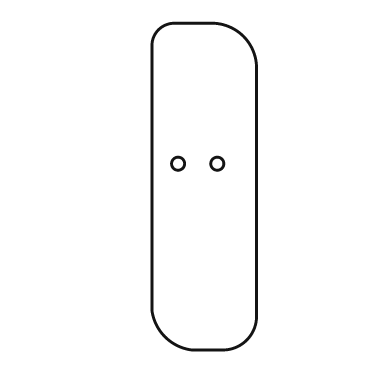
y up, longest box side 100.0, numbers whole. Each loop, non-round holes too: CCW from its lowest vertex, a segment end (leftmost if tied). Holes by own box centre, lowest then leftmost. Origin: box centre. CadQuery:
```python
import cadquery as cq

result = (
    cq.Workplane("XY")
    .moveTo(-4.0, -50.0)
    .lineTo(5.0, -50.0)
    .threePointArc((13.0, -47.0), (16.0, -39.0))
    .lineTo(16.0, 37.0)
    .threePointArc((12.0, 46.0), (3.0, 50.0))
    .lineTo(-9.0, 50.0)
    .threePointArc((-14.0, 48.0), (-16.0, 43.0))
    .lineTo(-16.0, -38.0)
    .threePointArc((-12.0, -46.0), (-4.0, -50.0))
    .close()
    .moveTo(-8.0, 7.0)
    .circle(2.0)
    .moveTo(4.0, 7.0)
    .circle(2.0)
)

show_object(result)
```